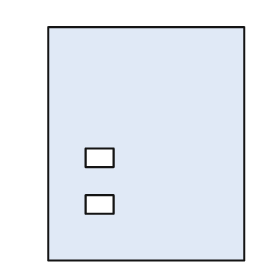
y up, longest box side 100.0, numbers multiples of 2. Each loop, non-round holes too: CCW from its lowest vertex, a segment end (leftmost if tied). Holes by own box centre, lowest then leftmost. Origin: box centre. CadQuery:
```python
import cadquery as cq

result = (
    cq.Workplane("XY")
    .moveTo(-42.0, -50.0)
    .lineTo(42.0, -50.0)
    .lineTo(42.0, 50.0)
    .lineTo(-42.0, 50.0)
    .close()
    .moveTo(-26.0, -30.0)
    .lineTo(-14.0, -30.0)
    .lineTo(-14.0, -22.0)
    .lineTo(-26.0, -22.0)
    .close()
    .moveTo(-26.0, -10.0)
    .lineTo(-14.0, -10.0)
    .lineTo(-14.0, -2.0)
    .lineTo(-26.0, -2.0)
    .close()
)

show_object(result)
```